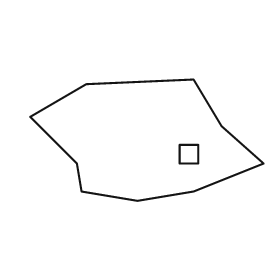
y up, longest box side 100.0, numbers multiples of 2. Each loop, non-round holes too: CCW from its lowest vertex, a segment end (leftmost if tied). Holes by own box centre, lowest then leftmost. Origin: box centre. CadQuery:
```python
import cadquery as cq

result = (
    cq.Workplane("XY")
    .moveTo(-4.0, -26.0)
    .lineTo(20.0, -22.0)
    .lineTo(50.0, -10.0)
    .lineTo(32.0, 6.0)
    .lineTo(20.0, 26.0)
    .lineTo(-26.0, 24.0)
    .lineTo(-50.0, 10.0)
    .lineTo(-30.0, -10.0)
    .lineTo(-28.0, -22.0)
    .close()
    .moveTo(14.0, -10.0)
    .lineTo(22.0, -10.0)
    .lineTo(22.0, -2.0)
    .lineTo(14.0, -2.0)
    .close()
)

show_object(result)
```